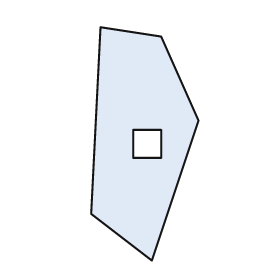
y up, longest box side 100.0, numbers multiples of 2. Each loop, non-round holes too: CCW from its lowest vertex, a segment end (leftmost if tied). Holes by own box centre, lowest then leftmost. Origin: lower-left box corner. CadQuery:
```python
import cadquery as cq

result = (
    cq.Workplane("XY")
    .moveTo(26.0, 0.0)
    .lineTo(46.0, 60.0)
    .lineTo(30.0, 96.0)
    .lineTo(4.0, 100.0)
    .lineTo(0.0, 20.0)
    .close()
    .moveTo(18.0, 44.0)
    .lineTo(30.0, 44.0)
    .lineTo(30.0, 56.0)
    .lineTo(18.0, 56.0)
    .close()
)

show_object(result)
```